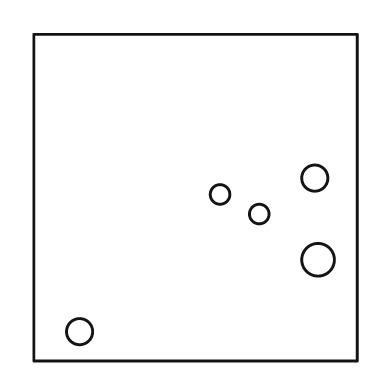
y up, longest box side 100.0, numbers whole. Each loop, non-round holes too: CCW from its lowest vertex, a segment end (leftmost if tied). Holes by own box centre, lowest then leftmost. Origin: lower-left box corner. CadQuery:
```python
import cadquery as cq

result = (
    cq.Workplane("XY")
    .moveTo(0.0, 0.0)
    .lineTo(99.0, 0.0)
    .lineTo(99.0, 100.0)
    .lineTo(0.0, 100.0)
    .close()
    .moveTo(14.0, 9.0)
    .circle(4.0)
    .moveTo(87.0, 31.0)
    .circle(5.0)
    .moveTo(69.0, 45.0)
    .circle(3.0)
    .moveTo(57.0, 51.0)
    .circle(3.0)
    .moveTo(86.0, 56.0)
    .circle(4.0)
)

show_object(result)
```